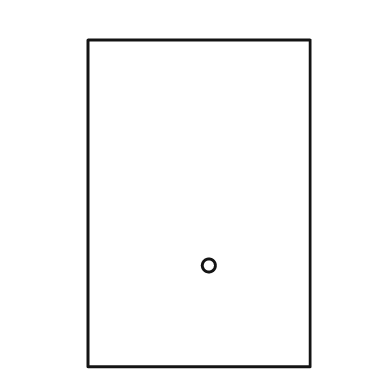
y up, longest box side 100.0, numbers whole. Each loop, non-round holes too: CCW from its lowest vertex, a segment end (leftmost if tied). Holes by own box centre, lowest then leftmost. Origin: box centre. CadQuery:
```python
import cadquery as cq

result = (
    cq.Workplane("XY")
    .moveTo(-34.0, -50.0)
    .lineTo(34.0, -50.0)
    .lineTo(34.0, 50.0)
    .lineTo(-34.0, 50.0)
    .close()
    .moveTo(3.0, -19.0)
    .circle(2.0)
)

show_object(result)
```